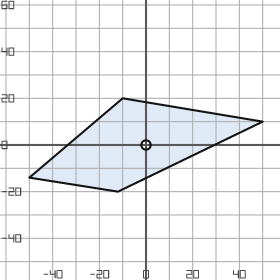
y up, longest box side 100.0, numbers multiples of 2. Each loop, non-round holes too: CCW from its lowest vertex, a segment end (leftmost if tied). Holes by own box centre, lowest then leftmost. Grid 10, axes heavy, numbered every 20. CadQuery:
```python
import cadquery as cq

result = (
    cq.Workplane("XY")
    .moveTo(-12.0, -20.0)
    .lineTo(50.0, 10.0)
    .lineTo(-10.0, 20.0)
    .lineTo(-50.0, -14.0)
    .close()
    .moveTo(0.0, 0.0)
    .circle(2.0)
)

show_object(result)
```